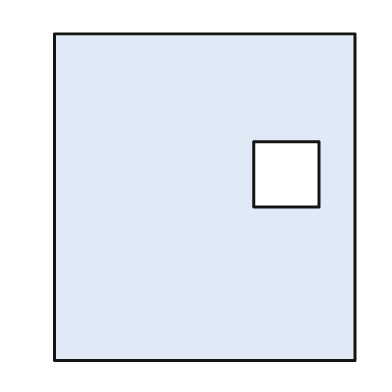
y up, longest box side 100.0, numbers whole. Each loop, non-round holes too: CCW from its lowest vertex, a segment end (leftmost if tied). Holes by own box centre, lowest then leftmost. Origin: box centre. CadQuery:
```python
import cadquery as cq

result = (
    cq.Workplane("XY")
    .moveTo(-46.0, -50.0)
    .lineTo(46.0, -50.0)
    .lineTo(46.0, 50.0)
    .lineTo(-46.0, 50.0)
    .close()
    .moveTo(15.0, -3.0)
    .lineTo(35.0, -3.0)
    .lineTo(35.0, 17.0)
    .lineTo(15.0, 17.0)
    .close()
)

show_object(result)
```